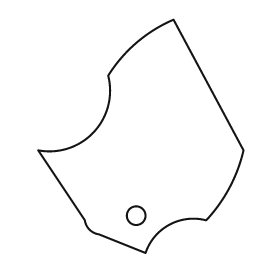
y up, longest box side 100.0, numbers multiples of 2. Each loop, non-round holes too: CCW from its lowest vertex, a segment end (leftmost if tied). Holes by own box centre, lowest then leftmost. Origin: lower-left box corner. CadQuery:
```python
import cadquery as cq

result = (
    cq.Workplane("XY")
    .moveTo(46.0, 0.0)
    .threePointArc((56.0, 12.0), (72.0, 14.0))
    .threePointArc((82.0, 28.0), (88.0, 44.0))
    .lineTo(58.0, 100.0)
    .threePointArc((42.0, 90.0), (30.0, 76.0))
    .threePointArc((24.0, 52.0), (0.0, 44.0))
    .lineTo(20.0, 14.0)
    .threePointArc((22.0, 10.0), (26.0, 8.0))
    .close()
    .moveTo(42.0, 16.0)
    .circle(4.0)
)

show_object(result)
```